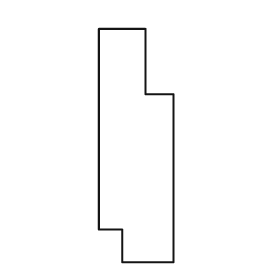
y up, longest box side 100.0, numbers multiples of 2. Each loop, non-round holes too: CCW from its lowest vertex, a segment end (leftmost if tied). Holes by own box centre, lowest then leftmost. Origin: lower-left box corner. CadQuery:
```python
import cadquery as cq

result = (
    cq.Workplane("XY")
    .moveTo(10.0, 0.0)
    .lineTo(32.0, 0.0)
    .lineTo(32.0, 72.0)
    .lineTo(20.0, 72.0)
    .lineTo(20.0, 100.0)
    .lineTo(0.0, 100.0)
    .lineTo(0.0, 14.0)
    .lineTo(10.0, 14.0)
    .close()
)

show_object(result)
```